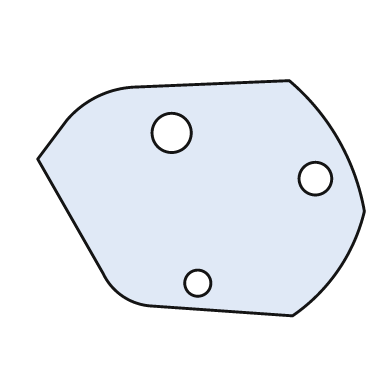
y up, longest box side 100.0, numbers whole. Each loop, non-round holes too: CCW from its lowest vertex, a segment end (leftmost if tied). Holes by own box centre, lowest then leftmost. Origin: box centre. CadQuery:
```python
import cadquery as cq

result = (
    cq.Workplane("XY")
    .moveTo(28.0, -36.0)
    .threePointArc((42.0, -22.0), (50.0, -4.0))
    .threePointArc((42.0, 18.0), (27.0, 36.0))
    .lineTo(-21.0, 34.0)
    .threePointArc((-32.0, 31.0), (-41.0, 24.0))
    .lineTo(-50.0, 12.0)
    .lineTo(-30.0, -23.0)
    .threePointArc((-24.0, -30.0), (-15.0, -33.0))
    .close()
    .moveTo(-1.0, -26.0)
    .circle(4.0)
    .moveTo(35.0, 6.0)
    .circle(5.0)
    .moveTo(-9.0, 20.0)
    .circle(6.0)
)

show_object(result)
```